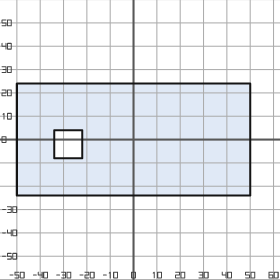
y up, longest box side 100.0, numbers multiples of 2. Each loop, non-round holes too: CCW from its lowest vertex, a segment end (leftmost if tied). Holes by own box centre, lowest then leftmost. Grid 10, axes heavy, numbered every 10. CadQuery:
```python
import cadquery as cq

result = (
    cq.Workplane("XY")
    .moveTo(-50.0, -24.0)
    .lineTo(50.0, -24.0)
    .lineTo(50.0, 24.0)
    .lineTo(-50.0, 24.0)
    .close()
    .moveTo(-34.0, -8.0)
    .lineTo(-22.0, -8.0)
    .lineTo(-22.0, 4.0)
    .lineTo(-34.0, 4.0)
    .close()
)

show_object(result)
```